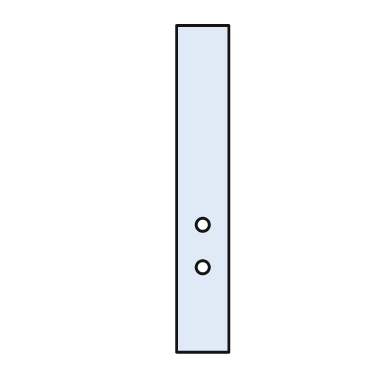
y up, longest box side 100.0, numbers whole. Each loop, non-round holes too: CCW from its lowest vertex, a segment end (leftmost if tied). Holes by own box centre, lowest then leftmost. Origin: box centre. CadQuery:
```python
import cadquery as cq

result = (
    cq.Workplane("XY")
    .moveTo(-8.0, -50.0)
    .lineTo(8.0, -50.0)
    .lineTo(8.0, 50.0)
    .lineTo(-8.0, 50.0)
    .close()
    .moveTo(0.0, -24.0)
    .circle(2.0)
    .moveTo(0.0, -11.0)
    .circle(2.0)
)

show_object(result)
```